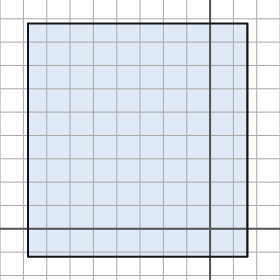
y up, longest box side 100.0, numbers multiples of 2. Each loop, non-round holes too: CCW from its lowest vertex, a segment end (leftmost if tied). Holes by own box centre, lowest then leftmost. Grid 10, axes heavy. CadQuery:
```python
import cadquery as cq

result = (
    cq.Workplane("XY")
    .moveTo(-78.0, -12.0)
    .lineTo(16.0, -12.0)
    .lineTo(16.0, 88.0)
    .lineTo(-78.0, 88.0)
    .close()
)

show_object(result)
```